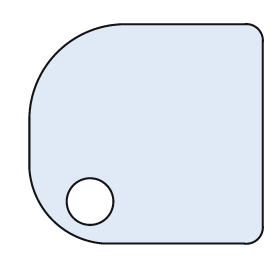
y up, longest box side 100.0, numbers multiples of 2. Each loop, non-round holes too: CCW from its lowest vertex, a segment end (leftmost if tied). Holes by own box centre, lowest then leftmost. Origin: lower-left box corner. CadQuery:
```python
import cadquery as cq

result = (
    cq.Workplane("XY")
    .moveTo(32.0, 0.0)
    .lineTo(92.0, 0.0)
    .threePointArc((98.0, 2.0), (100.0, 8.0))
    .lineTo(100.0, 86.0)
    .threePointArc((98.0, 92.0), (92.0, 94.0))
    .lineTo(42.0, 94.0)
    .threePointArc((12.0, 82.0), (0.0, 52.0))
    .lineTo(0.0, 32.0)
    .threePointArc((10.0, 10.0), (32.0, 0.0))
    .close()
    .moveTo(26.0, 18.0)
    .circle(10.0)
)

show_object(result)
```